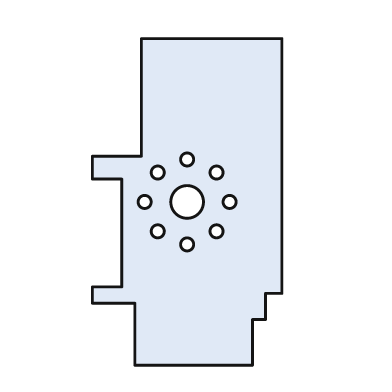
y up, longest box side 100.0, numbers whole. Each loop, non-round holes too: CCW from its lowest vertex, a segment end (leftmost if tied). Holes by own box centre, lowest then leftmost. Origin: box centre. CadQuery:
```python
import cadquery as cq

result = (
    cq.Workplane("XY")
    .moveTo(-16.0, -50.0)
    .lineTo(20.0, -50.0)
    .lineTo(20.0, -36.0)
    .lineTo(24.0, -36.0)
    .lineTo(24.0, -28.0)
    .lineTo(29.0, -28.0)
    .lineTo(29.0, 50.0)
    .lineTo(-14.0, 50.0)
    .lineTo(-14.0, 14.0)
    .lineTo(-29.0, 14.0)
    .lineTo(-29.0, 7.0)
    .lineTo(-20.0, 7.0)
    .lineTo(-20.0, -26.0)
    .lineTo(-29.0, -26.0)
    .lineTo(-29.0, -31.0)
    .lineTo(-16.0, -31.0)
    .close()
    .moveTo(0.0, -13.0)
    .circle(2.0)
    .moveTo(-9.0, -9.0)
    .circle(2.0)
    .moveTo(9.0, -9.0)
    .circle(2.0)
    .moveTo(-13.0, 0.0)
    .circle(2.0)
    .moveTo(0.0, 0.0)
    .circle(5.0)
    .moveTo(13.0, 0.0)
    .circle(2.0)
    .moveTo(-9.0, 9.0)
    .circle(2.0)
    .moveTo(9.0, 9.0)
    .circle(2.0)
    .moveTo(0.0, 13.0)
    .circle(2.0)
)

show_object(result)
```